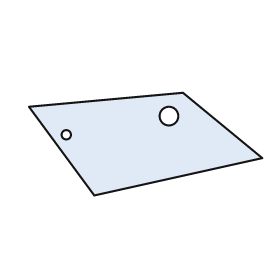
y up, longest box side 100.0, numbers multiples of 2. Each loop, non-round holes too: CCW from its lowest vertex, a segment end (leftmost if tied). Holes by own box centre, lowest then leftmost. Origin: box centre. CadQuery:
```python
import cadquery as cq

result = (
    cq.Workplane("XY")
    .moveTo(-22.0, -22.0)
    .lineTo(50.0, -6.0)
    .lineTo(16.0, 22.0)
    .lineTo(-50.0, 16.0)
    .close()
    .moveTo(-34.0, 4.0)
    .circle(2.0)
    .moveTo(10.0, 12.0)
    .circle(4.0)
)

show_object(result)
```